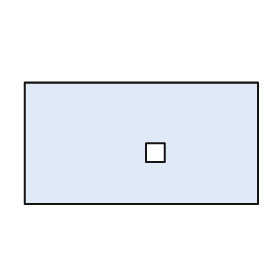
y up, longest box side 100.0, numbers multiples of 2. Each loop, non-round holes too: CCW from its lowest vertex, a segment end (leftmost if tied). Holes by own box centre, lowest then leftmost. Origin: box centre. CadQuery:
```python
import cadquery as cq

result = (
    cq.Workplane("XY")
    .moveTo(-50.0, -26.0)
    .lineTo(50.0, -26.0)
    .lineTo(50.0, 26.0)
    .lineTo(-50.0, 26.0)
    .close()
    .moveTo(2.0, -8.0)
    .lineTo(10.0, -8.0)
    .lineTo(10.0, 0.0)
    .lineTo(2.0, 0.0)
    .close()
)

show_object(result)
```